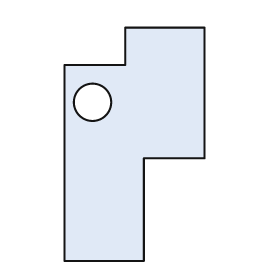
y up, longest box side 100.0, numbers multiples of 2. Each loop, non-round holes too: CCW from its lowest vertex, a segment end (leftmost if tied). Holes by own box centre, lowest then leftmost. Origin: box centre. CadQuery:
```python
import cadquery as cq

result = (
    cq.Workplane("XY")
    .moveTo(-30.0, -50.0)
    .lineTo(4.0, -50.0)
    .lineTo(4.0, -6.0)
    .lineTo(30.0, -6.0)
    .lineTo(30.0, 50.0)
    .lineTo(-4.0, 50.0)
    .lineTo(-4.0, 34.0)
    .lineTo(-30.0, 34.0)
    .close()
    .moveTo(-18.0, 18.0)
    .circle(8.0)
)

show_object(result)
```